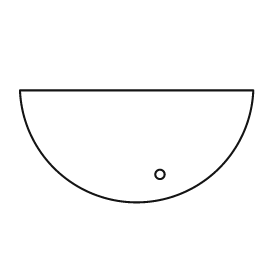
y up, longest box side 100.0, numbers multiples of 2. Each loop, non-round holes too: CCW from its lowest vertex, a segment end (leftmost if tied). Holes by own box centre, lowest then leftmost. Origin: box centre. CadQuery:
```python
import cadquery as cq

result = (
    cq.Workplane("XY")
    .moveTo(-50.0, 24.0)
    .threePointArc((0.0, -24.0), (50.0, 24.0))
    .close()
    .moveTo(10.0, -12.0)
    .circle(2.0)
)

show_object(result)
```